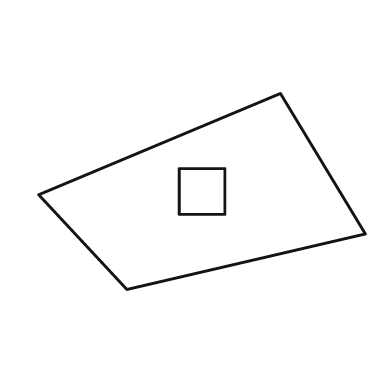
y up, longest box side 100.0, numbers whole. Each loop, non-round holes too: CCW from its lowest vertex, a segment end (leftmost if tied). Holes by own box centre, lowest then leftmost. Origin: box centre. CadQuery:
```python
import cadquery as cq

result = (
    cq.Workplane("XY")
    .moveTo(-23.0, -30.0)
    .lineTo(50.0, -13.0)
    .lineTo(24.0, 30.0)
    .lineTo(-50.0, -1.0)
    .close()
    .moveTo(-7.0, -7.0)
    .lineTo(7.0, -7.0)
    .lineTo(7.0, 7.0)
    .lineTo(-7.0, 7.0)
    .close()
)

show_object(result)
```